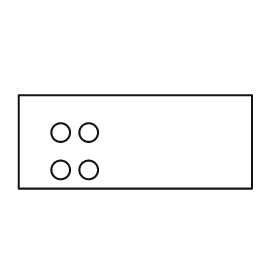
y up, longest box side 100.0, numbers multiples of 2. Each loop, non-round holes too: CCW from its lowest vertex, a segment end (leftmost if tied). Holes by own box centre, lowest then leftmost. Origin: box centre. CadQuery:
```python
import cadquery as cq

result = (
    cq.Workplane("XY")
    .moveTo(-50.0, -20.0)
    .lineTo(50.0, -20.0)
    .lineTo(50.0, 20.0)
    .lineTo(-50.0, 20.0)
    .close()
    .moveTo(-32.0, -12.0)
    .circle(4.0)
    .moveTo(-20.0, -12.0)
    .circle(4.0)
    .moveTo(-32.0, 4.0)
    .circle(4.0)
    .moveTo(-20.0, 4.0)
    .circle(4.0)
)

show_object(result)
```